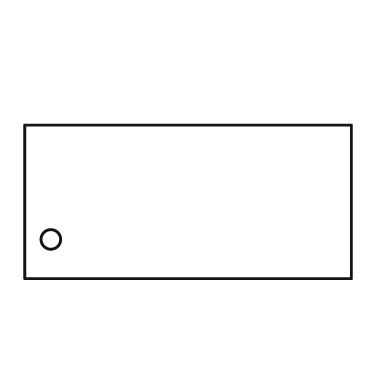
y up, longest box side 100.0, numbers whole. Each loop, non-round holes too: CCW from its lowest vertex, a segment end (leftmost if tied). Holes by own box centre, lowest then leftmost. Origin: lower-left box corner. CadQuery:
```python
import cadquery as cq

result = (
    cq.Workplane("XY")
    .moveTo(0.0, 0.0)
    .lineTo(100.0, 0.0)
    .lineTo(100.0, 47.0)
    .lineTo(0.0, 47.0)
    .close()
    .moveTo(8.0, 12.0)
    .circle(3.0)
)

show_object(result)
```